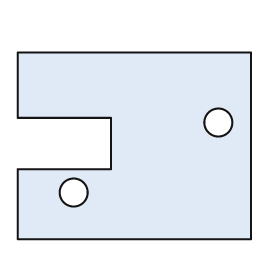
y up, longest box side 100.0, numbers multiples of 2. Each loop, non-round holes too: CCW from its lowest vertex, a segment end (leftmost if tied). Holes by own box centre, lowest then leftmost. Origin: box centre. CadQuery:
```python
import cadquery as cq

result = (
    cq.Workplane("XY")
    .moveTo(-50.0, -40.0)
    .lineTo(50.0, -40.0)
    .lineTo(50.0, 40.0)
    .lineTo(-50.0, 40.0)
    .lineTo(-50.0, 12.0)
    .lineTo(-10.0, 12.0)
    .lineTo(-10.0, -10.0)
    .lineTo(-50.0, -10.0)
    .close()
    .moveTo(-26.0, -20.0)
    .circle(6.0)
    .moveTo(36.0, 10.0)
    .circle(6.0)
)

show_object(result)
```